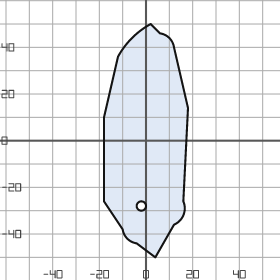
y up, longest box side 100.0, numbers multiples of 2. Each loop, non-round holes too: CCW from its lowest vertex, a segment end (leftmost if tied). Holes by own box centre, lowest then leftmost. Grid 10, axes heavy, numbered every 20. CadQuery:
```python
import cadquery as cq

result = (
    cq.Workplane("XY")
    .moveTo(4.0, -50.0)
    .lineTo(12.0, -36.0)
    .threePointArc((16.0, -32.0), (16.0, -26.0))
    .lineTo(18.0, 14.0)
    .lineTo(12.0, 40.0)
    .threePointArc((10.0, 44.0), (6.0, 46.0))
    .lineTo(2.0, 50.0)
    .threePointArc((-6.0, 44.0), (-12.0, 36.0))
    .lineTo(-18.0, 10.0)
    .lineTo(-18.0, -26.0)
    .lineTo(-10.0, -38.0)
    .threePointArc((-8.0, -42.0), (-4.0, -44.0))
    .close()
    .moveTo(-2.0, -28.0)
    .circle(2.0)
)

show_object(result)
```